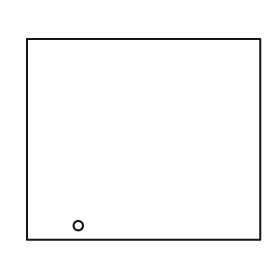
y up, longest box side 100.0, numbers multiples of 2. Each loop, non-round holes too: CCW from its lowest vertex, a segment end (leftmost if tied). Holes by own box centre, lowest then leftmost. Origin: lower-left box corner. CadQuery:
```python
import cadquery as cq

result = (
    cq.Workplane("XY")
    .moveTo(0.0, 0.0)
    .lineTo(100.0, 0.0)
    .lineTo(100.0, 86.0)
    .lineTo(0.0, 86.0)
    .close()
    .moveTo(22.0, 6.0)
    .circle(2.0)
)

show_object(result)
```